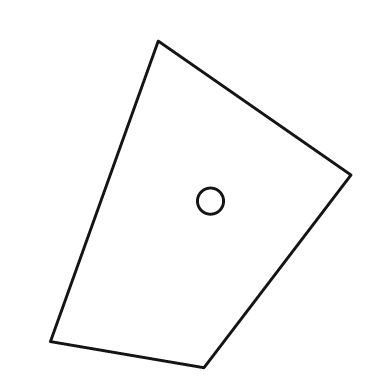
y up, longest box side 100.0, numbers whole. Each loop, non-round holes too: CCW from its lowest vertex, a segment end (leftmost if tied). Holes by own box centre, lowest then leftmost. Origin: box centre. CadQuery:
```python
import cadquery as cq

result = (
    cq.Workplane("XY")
    .moveTo(1.0, -50.0)
    .lineTo(46.0, 9.0)
    .lineTo(-13.0, 50.0)
    .lineTo(-46.0, -42.0)
    .close()
    .moveTo(3.0, 1.0)
    .circle(4.0)
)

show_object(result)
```